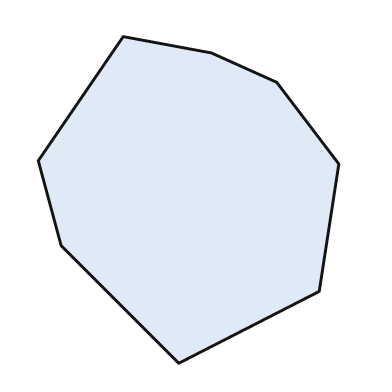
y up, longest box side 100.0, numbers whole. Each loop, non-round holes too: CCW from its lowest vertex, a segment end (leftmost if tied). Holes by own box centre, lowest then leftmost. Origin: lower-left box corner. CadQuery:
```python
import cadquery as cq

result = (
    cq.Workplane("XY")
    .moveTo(43.0, 0.0)
    .lineTo(86.0, 22.0)
    .lineTo(92.0, 61.0)
    .lineTo(73.0, 86.0)
    .lineTo(53.0, 95.0)
    .lineTo(26.0, 100.0)
    .lineTo(0.0, 62.0)
    .lineTo(7.0, 36.0)
    .close()
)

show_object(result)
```